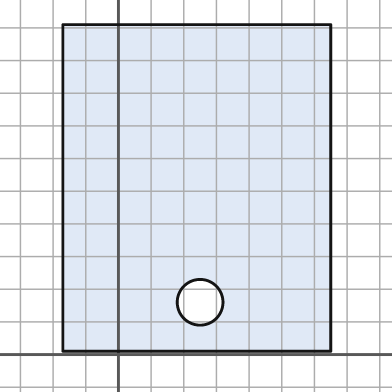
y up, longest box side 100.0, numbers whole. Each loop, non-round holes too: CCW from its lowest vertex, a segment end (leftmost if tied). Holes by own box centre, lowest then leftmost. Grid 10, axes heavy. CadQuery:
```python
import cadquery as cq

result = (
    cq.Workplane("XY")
    .moveTo(-17.0, 1.0)
    .lineTo(65.0, 1.0)
    .lineTo(65.0, 101.0)
    .lineTo(-17.0, 101.0)
    .close()
    .moveTo(25.0, 16.0)
    .circle(7.0)
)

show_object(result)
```